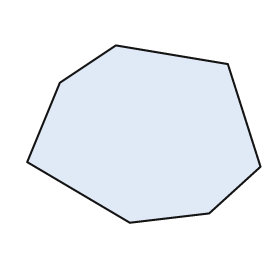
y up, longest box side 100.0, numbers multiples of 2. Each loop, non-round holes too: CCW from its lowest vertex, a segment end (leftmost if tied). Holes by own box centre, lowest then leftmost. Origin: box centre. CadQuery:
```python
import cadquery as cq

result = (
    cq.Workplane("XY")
    .moveTo(-6.0, -38.0)
    .lineTo(28.0, -34.0)
    .lineTo(50.0, -14.0)
    .lineTo(36.0, 30.0)
    .lineTo(-12.0, 38.0)
    .lineTo(-36.0, 22.0)
    .lineTo(-50.0, -12.0)
    .close()
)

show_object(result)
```